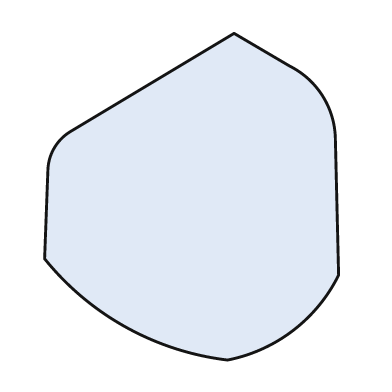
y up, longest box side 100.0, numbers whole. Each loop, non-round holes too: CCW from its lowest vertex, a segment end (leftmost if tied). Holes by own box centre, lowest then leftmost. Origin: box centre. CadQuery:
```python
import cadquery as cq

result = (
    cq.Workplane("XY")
    .moveTo(11.0, -50.0)
    .threePointArc((31.0, -41.0), (45.0, -24.0))
    .lineTo(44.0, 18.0)
    .threePointArc((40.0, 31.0), (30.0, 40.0))
    .lineTo(13.0, 50.0)
    .lineTo(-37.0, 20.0)
    .threePointArc((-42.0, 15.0), (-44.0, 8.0))
    .lineTo(-45.0, -19.0)
    .threePointArc((-20.0, -40.0), (11.0, -50.0))
    .close()
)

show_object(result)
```